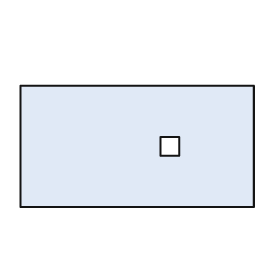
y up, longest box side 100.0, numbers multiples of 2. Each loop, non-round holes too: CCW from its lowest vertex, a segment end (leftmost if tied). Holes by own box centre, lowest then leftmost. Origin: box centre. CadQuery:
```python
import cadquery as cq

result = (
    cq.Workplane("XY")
    .moveTo(-50.0, -26.0)
    .lineTo(50.0, -26.0)
    .lineTo(50.0, 26.0)
    .lineTo(-50.0, 26.0)
    .close()
    .moveTo(10.0, -4.0)
    .lineTo(18.0, -4.0)
    .lineTo(18.0, 4.0)
    .lineTo(10.0, 4.0)
    .close()
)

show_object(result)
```